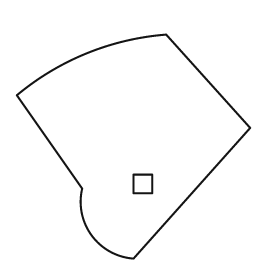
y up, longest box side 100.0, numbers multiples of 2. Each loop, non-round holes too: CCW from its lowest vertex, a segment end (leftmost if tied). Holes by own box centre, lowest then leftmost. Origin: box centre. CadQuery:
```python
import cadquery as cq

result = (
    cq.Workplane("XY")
    .moveTo(0.0, -48.0)
    .lineTo(50.0, 8.0)
    .lineTo(14.0, 48.0)
    .threePointArc((-20.0, 40.0), (-50.0, 22.0))
    .lineTo(-22.0, -18.0)
    .threePointArc((-18.0, -38.0), (0.0, -48.0))
    .close()
    .moveTo(0.0, -20.0)
    .lineTo(8.0, -20.0)
    .lineTo(8.0, -12.0)
    .lineTo(0.0, -12.0)
    .close()
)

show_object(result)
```